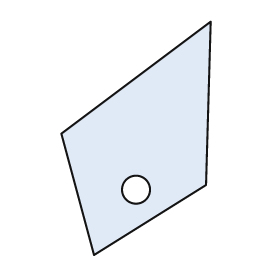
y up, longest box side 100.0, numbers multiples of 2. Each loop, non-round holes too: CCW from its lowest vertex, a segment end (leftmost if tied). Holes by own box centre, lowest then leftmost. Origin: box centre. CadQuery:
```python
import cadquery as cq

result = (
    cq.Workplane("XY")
    .moveTo(-18.0, -50.0)
    .lineTo(30.0, -20.0)
    .lineTo(32.0, 50.0)
    .lineTo(-32.0, 2.0)
    .close()
    .moveTo(0.0, -22.0)
    .circle(6.0)
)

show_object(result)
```